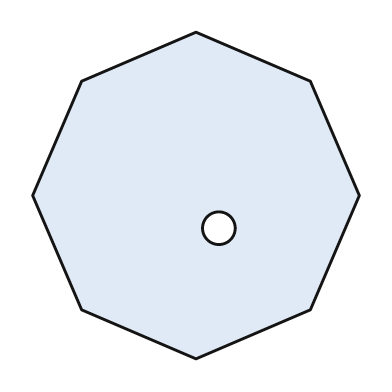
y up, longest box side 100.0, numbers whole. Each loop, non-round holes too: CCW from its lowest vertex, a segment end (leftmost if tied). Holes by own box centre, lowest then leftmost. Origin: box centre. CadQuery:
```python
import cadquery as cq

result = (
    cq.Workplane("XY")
    .moveTo(0.0, -50.0)
    .lineTo(35.0, -35.0)
    .lineTo(50.0, 0.0)
    .lineTo(35.0, 35.0)
    .lineTo(0.0, 50.0)
    .lineTo(-35.0, 35.0)
    .lineTo(-50.0, 0.0)
    .lineTo(-35.0, -35.0)
    .close()
    .moveTo(7.0, -10.0)
    .circle(5.0)
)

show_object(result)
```